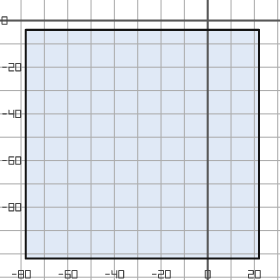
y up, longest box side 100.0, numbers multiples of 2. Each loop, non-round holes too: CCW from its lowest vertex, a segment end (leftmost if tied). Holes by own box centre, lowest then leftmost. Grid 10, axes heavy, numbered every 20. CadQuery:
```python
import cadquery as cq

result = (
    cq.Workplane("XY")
    .moveTo(-78.0, -102.0)
    .lineTo(22.0, -102.0)
    .lineTo(22.0, -4.0)
    .lineTo(-78.0, -4.0)
    .close()
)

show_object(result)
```